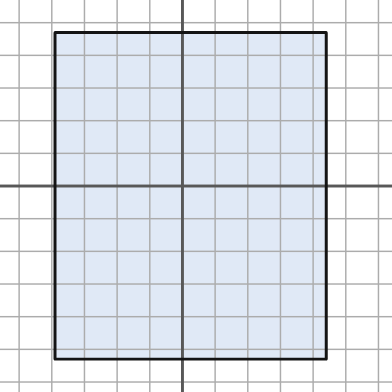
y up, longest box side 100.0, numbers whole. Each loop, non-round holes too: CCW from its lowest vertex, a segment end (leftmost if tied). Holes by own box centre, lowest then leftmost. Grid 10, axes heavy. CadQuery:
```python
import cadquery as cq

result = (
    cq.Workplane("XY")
    .moveTo(-39.0, -53.0)
    .lineTo(44.0, -53.0)
    .lineTo(44.0, 47.0)
    .lineTo(-39.0, 47.0)
    .close()
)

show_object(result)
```